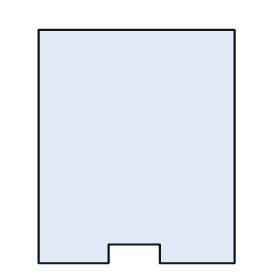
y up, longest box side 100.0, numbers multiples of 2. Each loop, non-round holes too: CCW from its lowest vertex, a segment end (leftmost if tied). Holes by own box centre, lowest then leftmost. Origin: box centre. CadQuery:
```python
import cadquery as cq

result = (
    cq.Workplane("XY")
    .moveTo(-42.0, -50.0)
    .lineTo(-12.0, -50.0)
    .lineTo(-12.0, -42.0)
    .lineTo(10.0, -42.0)
    .lineTo(10.0, -50.0)
    .lineTo(42.0, -50.0)
    .lineTo(42.0, 50.0)
    .lineTo(-42.0, 50.0)
    .close()
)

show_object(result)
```